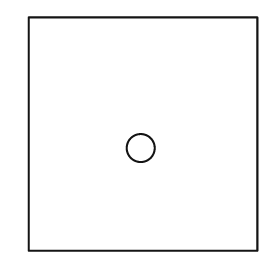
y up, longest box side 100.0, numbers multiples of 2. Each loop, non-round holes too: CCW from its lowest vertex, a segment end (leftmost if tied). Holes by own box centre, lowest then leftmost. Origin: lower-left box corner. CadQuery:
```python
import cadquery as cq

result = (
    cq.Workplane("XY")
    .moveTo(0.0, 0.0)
    .lineTo(98.0, 0.0)
    .lineTo(98.0, 100.0)
    .lineTo(0.0, 100.0)
    .close()
    .moveTo(48.0, 44.0)
    .circle(6.0)
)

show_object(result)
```